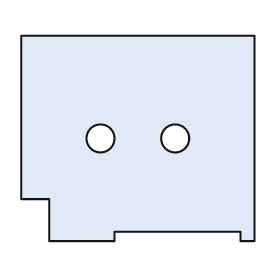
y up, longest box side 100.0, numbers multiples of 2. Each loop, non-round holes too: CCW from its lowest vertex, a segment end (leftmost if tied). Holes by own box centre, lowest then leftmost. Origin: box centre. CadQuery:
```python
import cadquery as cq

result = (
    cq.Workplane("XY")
    .moveTo(-38.0, -44.0)
    .lineTo(-10.0, -44.0)
    .lineTo(-10.0, -40.0)
    .lineTo(44.0, -40.0)
    .lineTo(44.0, -44.0)
    .lineTo(50.0, -44.0)
    .lineTo(50.0, 44.0)
    .lineTo(-50.0, 44.0)
    .lineTo(-50.0, -26.0)
    .lineTo(-38.0, -26.0)
    .close()
    .moveTo(-16.0, 0.0)
    .circle(6.0)
    .moveTo(16.0, 0.0)
    .circle(6.0)
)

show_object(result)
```